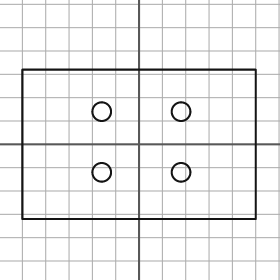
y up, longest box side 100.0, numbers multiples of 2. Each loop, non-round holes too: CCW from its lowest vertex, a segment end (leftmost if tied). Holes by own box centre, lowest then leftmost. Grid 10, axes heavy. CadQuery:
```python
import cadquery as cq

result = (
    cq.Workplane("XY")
    .moveTo(-50.0, -32.0)
    .lineTo(50.0, -32.0)
    .lineTo(50.0, 32.0)
    .lineTo(-50.0, 32.0)
    .close()
    .moveTo(-16.0, -12.0)
    .circle(4.0)
    .moveTo(18.0, -12.0)
    .circle(4.0)
    .moveTo(-16.0, 14.0)
    .circle(4.0)
    .moveTo(18.0, 14.0)
    .circle(4.0)
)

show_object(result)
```